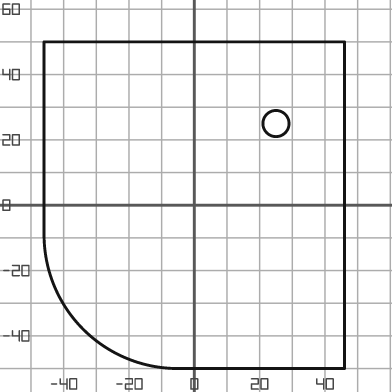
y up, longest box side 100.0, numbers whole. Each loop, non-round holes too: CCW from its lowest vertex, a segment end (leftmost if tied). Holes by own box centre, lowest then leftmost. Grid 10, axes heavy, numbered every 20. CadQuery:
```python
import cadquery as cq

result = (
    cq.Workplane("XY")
    .moveTo(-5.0, -50.0)
    .lineTo(46.0, -50.0)
    .lineTo(46.0, 50.0)
    .lineTo(-46.0, 50.0)
    .lineTo(-46.0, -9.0)
    .threePointArc((-34.0, -38.0), (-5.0, -50.0))
    .close()
    .moveTo(25.0, 25.0)
    .circle(4.0)
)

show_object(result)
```